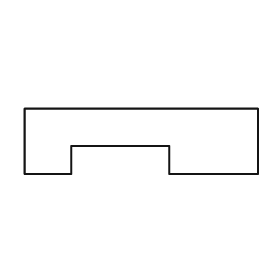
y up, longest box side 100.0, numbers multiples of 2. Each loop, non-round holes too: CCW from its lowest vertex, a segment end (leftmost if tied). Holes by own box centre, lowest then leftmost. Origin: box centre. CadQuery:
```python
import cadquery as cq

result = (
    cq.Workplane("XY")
    .moveTo(-50.0, -14.0)
    .lineTo(-30.0, -14.0)
    .lineTo(-30.0, -2.0)
    .lineTo(12.0, -2.0)
    .lineTo(12.0, -14.0)
    .lineTo(50.0, -14.0)
    .lineTo(50.0, 14.0)
    .lineTo(-50.0, 14.0)
    .close()
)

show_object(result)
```